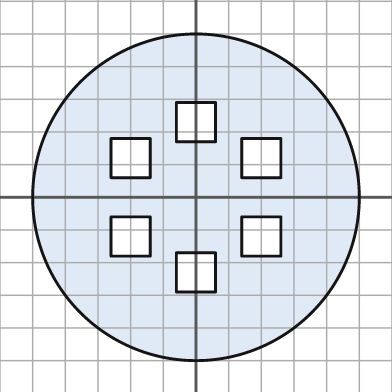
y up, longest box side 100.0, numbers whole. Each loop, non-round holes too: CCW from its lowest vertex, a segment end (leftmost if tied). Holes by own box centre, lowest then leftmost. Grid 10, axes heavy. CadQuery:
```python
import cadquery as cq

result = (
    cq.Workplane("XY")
    .moveTo(0.0, 0.0)
    .circle(50.0)
    .moveTo(-6.0, -29.0)
    .lineTo(6.0, -29.0)
    .lineTo(6.0, -17.0)
    .lineTo(-6.0, -17.0)
    .close()
    .moveTo(-26.0, -18.0)
    .lineTo(-14.0, -18.0)
    .lineTo(-14.0, -6.0)
    .lineTo(-26.0, -6.0)
    .close()
    .moveTo(14.0, -18.0)
    .lineTo(26.0, -18.0)
    .lineTo(26.0, -6.0)
    .lineTo(14.0, -6.0)
    .close()
    .moveTo(-26.0, 6.0)
    .lineTo(-14.0, 6.0)
    .lineTo(-14.0, 18.0)
    .lineTo(-26.0, 18.0)
    .close()
    .moveTo(14.0, 6.0)
    .lineTo(26.0, 6.0)
    .lineTo(26.0, 18.0)
    .lineTo(14.0, 18.0)
    .close()
    .moveTo(-6.0, 17.0)
    .lineTo(6.0, 17.0)
    .lineTo(6.0, 29.0)
    .lineTo(-6.0, 29.0)
    .close()
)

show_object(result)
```